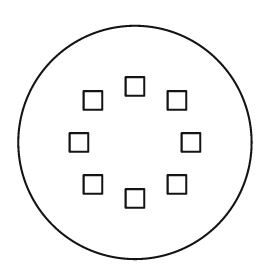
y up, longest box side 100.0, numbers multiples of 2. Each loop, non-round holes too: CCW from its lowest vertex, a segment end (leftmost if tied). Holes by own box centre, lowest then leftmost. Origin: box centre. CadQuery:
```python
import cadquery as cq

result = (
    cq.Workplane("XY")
    .moveTo(0.0, 0.0)
    .circle(50.0)
    .moveTo(-4.0, -28.0)
    .lineTo(4.0, -28.0)
    .lineTo(4.0, -20.0)
    .lineTo(-4.0, -20.0)
    .close()
    .moveTo(-22.0, -22.0)
    .lineTo(-14.0, -22.0)
    .lineTo(-14.0, -14.0)
    .lineTo(-22.0, -14.0)
    .close()
    .moveTo(14.0, -22.0)
    .lineTo(22.0, -22.0)
    .lineTo(22.0, -14.0)
    .lineTo(14.0, -14.0)
    .close()
    .moveTo(-28.0, -4.0)
    .lineTo(-20.0, -4.0)
    .lineTo(-20.0, 4.0)
    .lineTo(-28.0, 4.0)
    .close()
    .moveTo(20.0, -4.0)
    .lineTo(28.0, -4.0)
    .lineTo(28.0, 4.0)
    .lineTo(20.0, 4.0)
    .close()
    .moveTo(-22.0, 14.0)
    .lineTo(-14.0, 14.0)
    .lineTo(-14.0, 22.0)
    .lineTo(-22.0, 22.0)
    .close()
    .moveTo(14.0, 14.0)
    .lineTo(22.0, 14.0)
    .lineTo(22.0, 22.0)
    .lineTo(14.0, 22.0)
    .close()
    .moveTo(-4.0, 20.0)
    .lineTo(4.0, 20.0)
    .lineTo(4.0, 28.0)
    .lineTo(-4.0, 28.0)
    .close()
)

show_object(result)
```